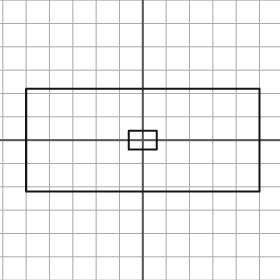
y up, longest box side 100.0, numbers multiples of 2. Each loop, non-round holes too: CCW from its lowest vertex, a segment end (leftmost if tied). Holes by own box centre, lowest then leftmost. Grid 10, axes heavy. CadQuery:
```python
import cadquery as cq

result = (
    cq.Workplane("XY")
    .moveTo(-50.0, -22.0)
    .lineTo(50.0, -22.0)
    .lineTo(50.0, 22.0)
    .lineTo(-50.0, 22.0)
    .close()
    .moveTo(-6.0, -4.0)
    .lineTo(6.0, -4.0)
    .lineTo(6.0, 4.0)
    .lineTo(-6.0, 4.0)
    .close()
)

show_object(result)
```